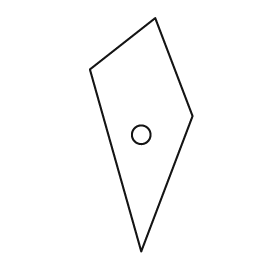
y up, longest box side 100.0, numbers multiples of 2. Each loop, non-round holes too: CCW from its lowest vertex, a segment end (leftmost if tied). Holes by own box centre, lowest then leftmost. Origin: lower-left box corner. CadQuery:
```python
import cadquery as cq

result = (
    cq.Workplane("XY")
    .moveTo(22.0, 0.0)
    .lineTo(44.0, 58.0)
    .lineTo(28.0, 100.0)
    .lineTo(0.0, 78.0)
    .close()
    .moveTo(22.0, 50.0)
    .circle(4.0)
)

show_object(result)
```